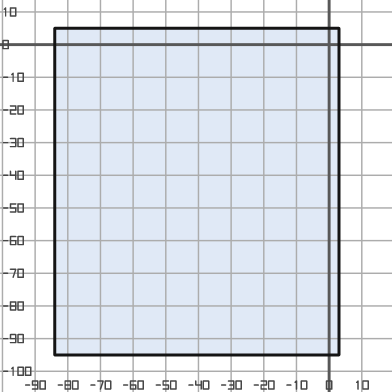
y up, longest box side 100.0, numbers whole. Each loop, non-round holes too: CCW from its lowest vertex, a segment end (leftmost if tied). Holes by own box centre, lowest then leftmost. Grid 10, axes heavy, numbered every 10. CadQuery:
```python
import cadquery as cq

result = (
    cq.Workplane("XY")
    .moveTo(-84.0, -95.0)
    .lineTo(3.0, -95.0)
    .lineTo(3.0, 5.0)
    .lineTo(-84.0, 5.0)
    .close()
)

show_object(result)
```